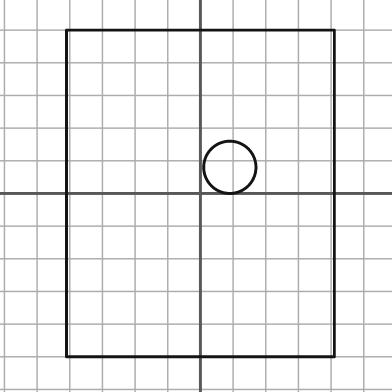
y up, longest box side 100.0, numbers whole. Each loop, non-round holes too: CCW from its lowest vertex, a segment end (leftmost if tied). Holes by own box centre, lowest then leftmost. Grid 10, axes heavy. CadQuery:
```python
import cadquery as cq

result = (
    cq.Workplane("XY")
    .moveTo(-41.0, -50.0)
    .lineTo(41.0, -50.0)
    .lineTo(41.0, 50.0)
    .lineTo(-41.0, 50.0)
    .close()
    .moveTo(9.0, 8.0)
    .circle(8.0)
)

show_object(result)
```